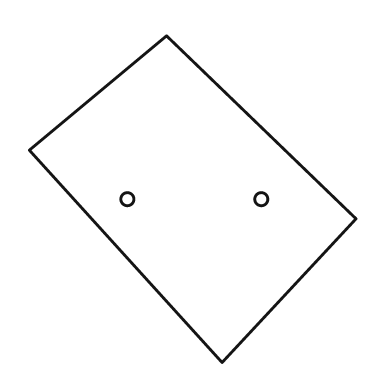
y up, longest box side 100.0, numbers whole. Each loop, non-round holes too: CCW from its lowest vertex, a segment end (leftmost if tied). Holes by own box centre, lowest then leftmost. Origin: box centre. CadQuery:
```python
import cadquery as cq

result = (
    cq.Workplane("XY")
    .moveTo(9.0, -50.0)
    .lineTo(50.0, -6.0)
    .lineTo(-8.0, 50.0)
    .lineTo(-50.0, 15.0)
    .close()
    .moveTo(-20.0, 0.0)
    .circle(2.0)
    .moveTo(21.0, 0.0)
    .circle(2.0)
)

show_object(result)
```